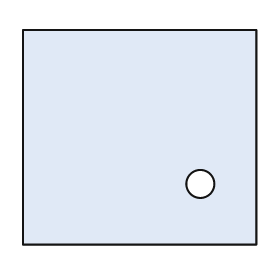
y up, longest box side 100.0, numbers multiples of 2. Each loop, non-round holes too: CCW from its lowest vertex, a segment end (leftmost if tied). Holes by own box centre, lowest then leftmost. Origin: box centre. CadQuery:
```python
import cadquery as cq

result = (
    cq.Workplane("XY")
    .moveTo(-50.0, -46.0)
    .lineTo(50.0, -46.0)
    .lineTo(50.0, 46.0)
    .lineTo(-50.0, 46.0)
    .close()
    .moveTo(26.0, -20.0)
    .circle(6.0)
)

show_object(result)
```